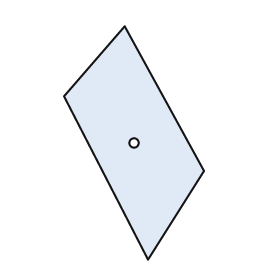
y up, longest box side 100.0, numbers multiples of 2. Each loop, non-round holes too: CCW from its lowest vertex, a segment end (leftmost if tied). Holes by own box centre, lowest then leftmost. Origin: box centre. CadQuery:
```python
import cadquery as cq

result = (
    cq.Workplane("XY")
    .moveTo(6.0, -50.0)
    .lineTo(30.0, -12.0)
    .lineTo(-4.0, 50.0)
    .lineTo(-30.0, 20.0)
    .close()
    .moveTo(0.0, 0.0)
    .circle(2.0)
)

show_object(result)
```